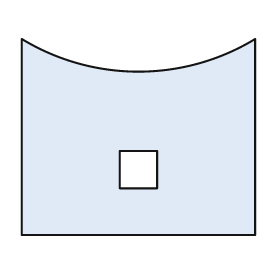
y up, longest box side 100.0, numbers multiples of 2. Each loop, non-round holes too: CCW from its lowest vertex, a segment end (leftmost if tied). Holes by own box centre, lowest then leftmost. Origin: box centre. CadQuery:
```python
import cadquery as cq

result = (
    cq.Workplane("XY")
    .moveTo(-50.0, -42.0)
    .lineTo(50.0, -42.0)
    .lineTo(50.0, 42.0)
    .threePointArc((0.0, 28.0), (-50.0, 42.0))
    .close()
    .moveTo(-8.0, -22.0)
    .lineTo(8.0, -22.0)
    .lineTo(8.0, -6.0)
    .lineTo(-8.0, -6.0)
    .close()
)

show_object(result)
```